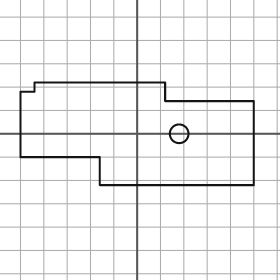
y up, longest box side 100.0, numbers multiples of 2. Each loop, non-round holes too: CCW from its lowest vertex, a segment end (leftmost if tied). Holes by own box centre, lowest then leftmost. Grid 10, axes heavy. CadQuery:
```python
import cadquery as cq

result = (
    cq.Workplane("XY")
    .moveTo(-16.0, -22.0)
    .lineTo(50.0, -22.0)
    .lineTo(50.0, 14.0)
    .lineTo(12.0, 14.0)
    .lineTo(12.0, 22.0)
    .lineTo(-44.0, 22.0)
    .lineTo(-44.0, 18.0)
    .lineTo(-50.0, 18.0)
    .lineTo(-50.0, -10.0)
    .lineTo(-16.0, -10.0)
    .close()
    .moveTo(18.0, 0.0)
    .circle(4.0)
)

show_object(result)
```